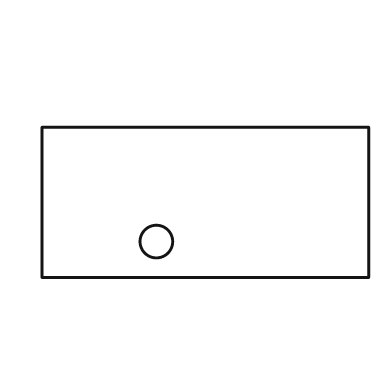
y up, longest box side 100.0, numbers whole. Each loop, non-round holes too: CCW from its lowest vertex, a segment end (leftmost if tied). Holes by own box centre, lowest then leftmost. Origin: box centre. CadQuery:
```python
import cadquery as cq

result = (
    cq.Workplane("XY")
    .moveTo(-50.0, -23.0)
    .lineTo(50.0, -23.0)
    .lineTo(50.0, 23.0)
    .lineTo(-50.0, 23.0)
    .close()
    .moveTo(-15.0, -12.0)
    .circle(5.0)
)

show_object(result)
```